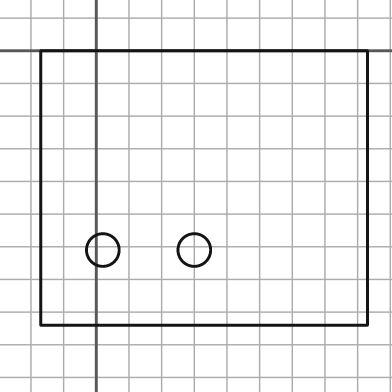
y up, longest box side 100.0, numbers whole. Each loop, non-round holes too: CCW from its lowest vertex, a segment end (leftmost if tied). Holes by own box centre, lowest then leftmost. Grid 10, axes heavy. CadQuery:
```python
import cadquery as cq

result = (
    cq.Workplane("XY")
    .moveTo(-17.0, -84.0)
    .lineTo(83.0, -84.0)
    .lineTo(83.0, 0.0)
    .lineTo(-17.0, 0.0)
    .close()
    .moveTo(2.0, -61.0)
    .circle(5.0)
    .moveTo(30.0, -61.0)
    .circle(5.0)
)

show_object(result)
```